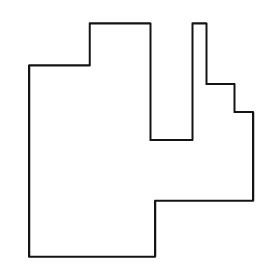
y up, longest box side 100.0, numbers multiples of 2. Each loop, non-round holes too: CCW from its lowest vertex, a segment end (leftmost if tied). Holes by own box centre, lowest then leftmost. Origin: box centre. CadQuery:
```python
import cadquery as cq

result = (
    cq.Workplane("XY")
    .moveTo(-48.0, -50.0)
    .lineTo(6.0, -50.0)
    .lineTo(6.0, -26.0)
    .lineTo(48.0, -26.0)
    .lineTo(48.0, 12.0)
    .lineTo(40.0, 12.0)
    .lineTo(40.0, 24.0)
    .lineTo(28.0, 24.0)
    .lineTo(28.0, 50.0)
    .lineTo(22.0, 50.0)
    .lineTo(22.0, 0.0)
    .lineTo(4.0, 0.0)
    .lineTo(4.0, 50.0)
    .lineTo(-22.0, 50.0)
    .lineTo(-22.0, 32.0)
    .lineTo(-48.0, 32.0)
    .close()
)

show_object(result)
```